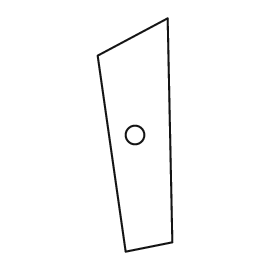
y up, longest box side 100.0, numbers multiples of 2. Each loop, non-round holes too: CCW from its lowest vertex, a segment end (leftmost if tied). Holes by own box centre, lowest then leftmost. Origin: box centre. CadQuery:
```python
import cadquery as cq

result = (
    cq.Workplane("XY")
    .moveTo(-4.0, -50.0)
    .lineTo(16.0, -46.0)
    .lineTo(14.0, 50.0)
    .lineTo(-16.0, 34.0)
    .close()
    .moveTo(0.0, 0.0)
    .circle(4.0)
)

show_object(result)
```